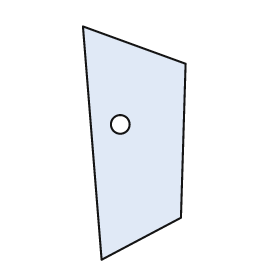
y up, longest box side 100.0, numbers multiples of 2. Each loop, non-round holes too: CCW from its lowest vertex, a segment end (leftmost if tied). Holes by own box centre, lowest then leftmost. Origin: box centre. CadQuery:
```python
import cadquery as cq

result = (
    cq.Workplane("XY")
    .moveTo(-14.0, -50.0)
    .lineTo(20.0, -32.0)
    .lineTo(22.0, 34.0)
    .lineTo(-22.0, 50.0)
    .close()
    .moveTo(-6.0, 8.0)
    .circle(4.0)
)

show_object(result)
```